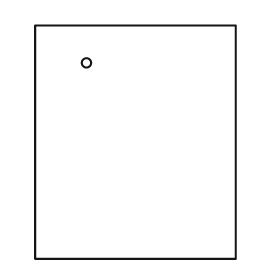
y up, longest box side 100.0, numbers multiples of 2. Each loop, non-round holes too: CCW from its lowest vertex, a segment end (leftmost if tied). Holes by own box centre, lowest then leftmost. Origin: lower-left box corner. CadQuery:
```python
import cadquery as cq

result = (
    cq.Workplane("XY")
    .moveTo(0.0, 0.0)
    .lineTo(86.0, 0.0)
    .lineTo(86.0, 100.0)
    .lineTo(0.0, 100.0)
    .close()
    .moveTo(22.0, 84.0)
    .circle(2.0)
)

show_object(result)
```